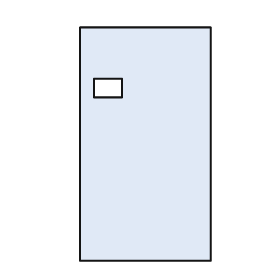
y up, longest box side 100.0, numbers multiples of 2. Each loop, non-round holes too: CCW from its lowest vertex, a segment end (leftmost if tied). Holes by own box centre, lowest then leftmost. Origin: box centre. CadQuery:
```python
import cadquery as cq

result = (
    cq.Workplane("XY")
    .moveTo(-28.0, -50.0)
    .lineTo(28.0, -50.0)
    .lineTo(28.0, 50.0)
    .lineTo(-28.0, 50.0)
    .close()
    .moveTo(-22.0, 20.0)
    .lineTo(-10.0, 20.0)
    .lineTo(-10.0, 28.0)
    .lineTo(-22.0, 28.0)
    .close()
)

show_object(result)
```